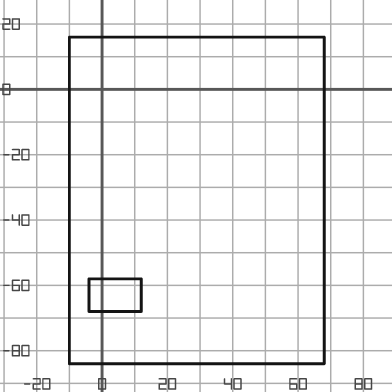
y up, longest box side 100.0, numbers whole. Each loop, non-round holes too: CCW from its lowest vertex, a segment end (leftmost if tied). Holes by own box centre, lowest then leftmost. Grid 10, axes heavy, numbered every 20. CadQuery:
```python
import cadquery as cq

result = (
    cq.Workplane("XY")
    .moveTo(-10.0, -84.0)
    .lineTo(68.0, -84.0)
    .lineTo(68.0, 16.0)
    .lineTo(-10.0, 16.0)
    .close()
    .moveTo(-4.0, -68.0)
    .lineTo(12.0, -68.0)
    .lineTo(12.0, -58.0)
    .lineTo(-4.0, -58.0)
    .close()
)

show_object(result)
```